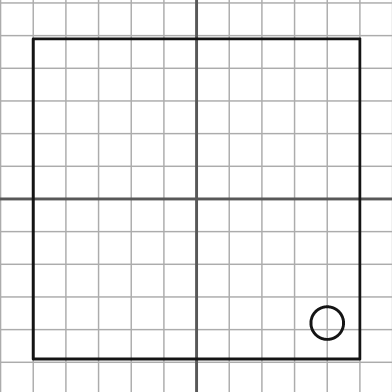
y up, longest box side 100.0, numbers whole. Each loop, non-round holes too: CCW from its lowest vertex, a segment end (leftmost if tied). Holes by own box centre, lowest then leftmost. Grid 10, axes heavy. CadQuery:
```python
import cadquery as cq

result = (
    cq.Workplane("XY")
    .moveTo(-50.0, -49.0)
    .lineTo(50.0, -49.0)
    .lineTo(50.0, 49.0)
    .lineTo(-50.0, 49.0)
    .close()
    .moveTo(40.0, -38.0)
    .circle(5.0)
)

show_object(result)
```